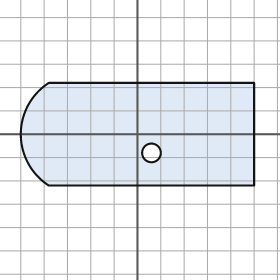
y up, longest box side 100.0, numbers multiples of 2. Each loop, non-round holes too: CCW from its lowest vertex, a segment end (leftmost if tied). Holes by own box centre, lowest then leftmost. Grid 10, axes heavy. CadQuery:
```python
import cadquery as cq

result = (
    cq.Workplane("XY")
    .moveTo(-38.0, -22.0)
    .lineTo(50.0, -22.0)
    .lineTo(50.0, 22.0)
    .lineTo(-38.0, 22.0)
    .threePointArc((-50.0, 0.0), (-38.0, -22.0))
    .close()
    .moveTo(6.0, -8.0)
    .circle(4.0)
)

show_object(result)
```